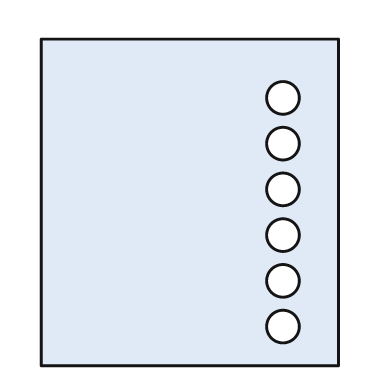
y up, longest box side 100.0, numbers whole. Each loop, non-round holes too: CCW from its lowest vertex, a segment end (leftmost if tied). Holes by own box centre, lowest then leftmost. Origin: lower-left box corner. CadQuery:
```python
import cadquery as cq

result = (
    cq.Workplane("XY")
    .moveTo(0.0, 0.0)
    .lineTo(91.0, 0.0)
    .lineTo(91.0, 100.0)
    .lineTo(0.0, 100.0)
    .close()
    .moveTo(74.0, 12.0)
    .circle(5.0)
    .moveTo(74.0, 26.0)
    .circle(5.0)
    .moveTo(74.0, 40.0)
    .circle(5.0)
    .moveTo(74.0, 54.0)
    .circle(5.0)
    .moveTo(74.0, 68.0)
    .circle(5.0)
    .moveTo(74.0, 82.0)
    .circle(5.0)
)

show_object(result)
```